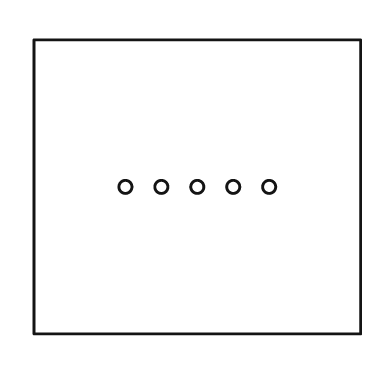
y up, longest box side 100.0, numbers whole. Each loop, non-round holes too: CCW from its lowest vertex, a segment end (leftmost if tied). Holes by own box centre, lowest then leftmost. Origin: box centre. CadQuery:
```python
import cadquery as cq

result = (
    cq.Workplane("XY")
    .moveTo(-50.0, -45.0)
    .lineTo(50.0, -45.0)
    .lineTo(50.0, 45.0)
    .lineTo(-50.0, 45.0)
    .close()
    .moveTo(-22.0, 0.0)
    .circle(2.0)
    .moveTo(-11.0, 0.0)
    .circle(2.0)
    .moveTo(0.0, 0.0)
    .circle(2.0)
    .moveTo(11.0, 0.0)
    .circle(2.0)
    .moveTo(22.0, 0.0)
    .circle(2.0)
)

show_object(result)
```